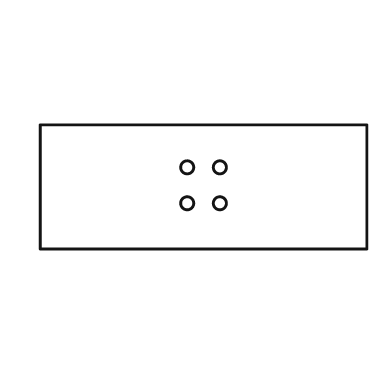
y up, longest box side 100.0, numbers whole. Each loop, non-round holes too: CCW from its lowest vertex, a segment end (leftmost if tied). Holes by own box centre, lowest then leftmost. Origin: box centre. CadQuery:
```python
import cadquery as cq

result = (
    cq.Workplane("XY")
    .moveTo(-50.0, -19.0)
    .lineTo(50.0, -19.0)
    .lineTo(50.0, 19.0)
    .lineTo(-50.0, 19.0)
    .close()
    .moveTo(-5.0, -5.0)
    .circle(2.0)
    .moveTo(5.0, -5.0)
    .circle(2.0)
    .moveTo(-5.0, 6.0)
    .circle(2.0)
    .moveTo(5.0, 6.0)
    .circle(2.0)
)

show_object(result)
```